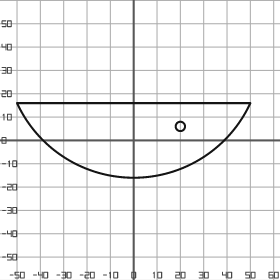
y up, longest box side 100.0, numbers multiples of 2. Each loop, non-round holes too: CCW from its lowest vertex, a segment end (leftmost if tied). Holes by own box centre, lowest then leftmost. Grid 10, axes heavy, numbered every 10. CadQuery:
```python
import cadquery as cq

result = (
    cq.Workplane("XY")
    .moveTo(-50.0, 16.0)
    .threePointArc((0.0, -16.0), (50.0, 16.0))
    .close()
    .moveTo(20.0, 6.0)
    .circle(2.0)
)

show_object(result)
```